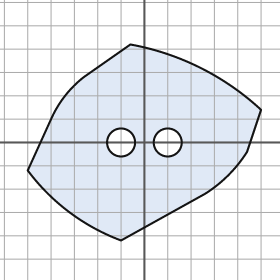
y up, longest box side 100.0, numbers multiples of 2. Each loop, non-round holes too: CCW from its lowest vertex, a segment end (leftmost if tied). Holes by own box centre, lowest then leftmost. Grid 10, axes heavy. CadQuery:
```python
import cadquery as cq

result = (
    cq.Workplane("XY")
    .moveTo(-10.0, -42.0)
    .lineTo(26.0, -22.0)
    .threePointArc((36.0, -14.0), (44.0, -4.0))
    .lineTo(50.0, 14.0)
    .threePointArc((24.0, 32.0), (-6.0, 42.0))
    .lineTo(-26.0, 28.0)
    .threePointArc((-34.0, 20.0), (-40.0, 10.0))
    .lineTo(-50.0, -12.0)
    .threePointArc((-32.0, -30.0), (-10.0, -42.0))
    .close()
    .moveTo(-10.0, 0.0)
    .circle(6.0)
    .moveTo(10.0, 0.0)
    .circle(6.0)
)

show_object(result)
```